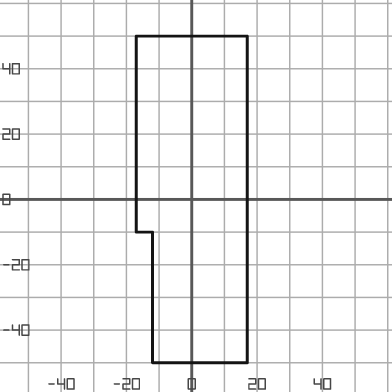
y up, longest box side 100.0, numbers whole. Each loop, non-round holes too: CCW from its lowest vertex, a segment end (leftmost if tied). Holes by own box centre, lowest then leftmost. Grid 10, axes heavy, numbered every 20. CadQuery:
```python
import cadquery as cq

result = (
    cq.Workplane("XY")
    .moveTo(-12.0, -50.0)
    .lineTo(17.0, -50.0)
    .lineTo(17.0, 50.0)
    .lineTo(-17.0, 50.0)
    .lineTo(-17.0, -10.0)
    .lineTo(-12.0, -10.0)
    .close()
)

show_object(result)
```